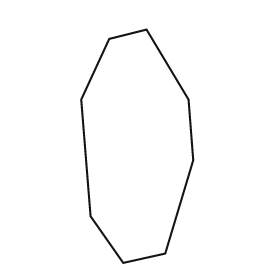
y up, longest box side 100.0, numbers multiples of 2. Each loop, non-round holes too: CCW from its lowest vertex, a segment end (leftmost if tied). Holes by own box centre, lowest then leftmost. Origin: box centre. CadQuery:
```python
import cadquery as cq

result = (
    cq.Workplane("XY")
    .moveTo(-6.0, -50.0)
    .lineTo(12.0, -46.0)
    .lineTo(24.0, -6.0)
    .lineTo(22.0, 20.0)
    .lineTo(4.0, 50.0)
    .lineTo(-12.0, 46.0)
    .lineTo(-24.0, 20.0)
    .lineTo(-20.0, -30.0)
    .close()
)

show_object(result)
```